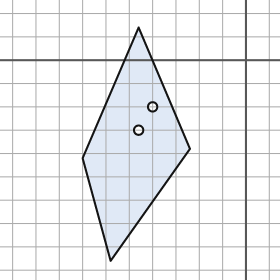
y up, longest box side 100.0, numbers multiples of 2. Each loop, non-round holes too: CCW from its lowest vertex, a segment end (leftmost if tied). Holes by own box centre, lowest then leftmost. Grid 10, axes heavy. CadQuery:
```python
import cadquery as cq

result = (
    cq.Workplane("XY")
    .moveTo(-58.0, -86.0)
    .lineTo(-24.0, -38.0)
    .lineTo(-46.0, 14.0)
    .lineTo(-70.0, -42.0)
    .close()
    .moveTo(-46.0, -30.0)
    .circle(2.0)
    .moveTo(-40.0, -20.0)
    .circle(2.0)
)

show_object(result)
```